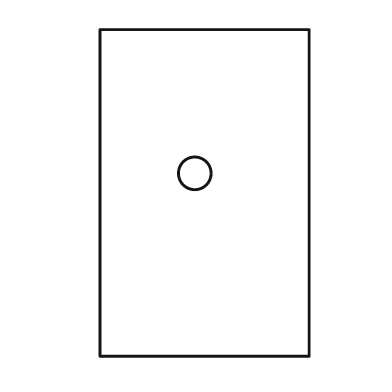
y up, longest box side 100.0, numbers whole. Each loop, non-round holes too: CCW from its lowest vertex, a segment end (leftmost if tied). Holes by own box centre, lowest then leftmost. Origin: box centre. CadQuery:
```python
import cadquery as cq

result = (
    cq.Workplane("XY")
    .moveTo(-32.0, -50.0)
    .lineTo(32.0, -50.0)
    .lineTo(32.0, 50.0)
    .lineTo(-32.0, 50.0)
    .close()
    .moveTo(-3.0, 6.0)
    .circle(5.0)
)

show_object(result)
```